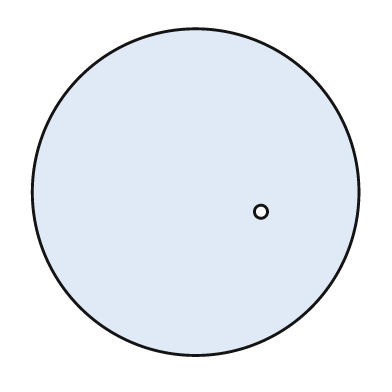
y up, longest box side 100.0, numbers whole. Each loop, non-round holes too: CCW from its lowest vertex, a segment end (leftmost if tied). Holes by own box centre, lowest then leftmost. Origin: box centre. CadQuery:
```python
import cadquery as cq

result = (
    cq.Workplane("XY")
    .moveTo(0.0, 0.0)
    .circle(50.0)
    .moveTo(20.0, -6.0)
    .circle(2.0)
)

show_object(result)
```